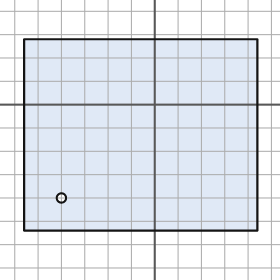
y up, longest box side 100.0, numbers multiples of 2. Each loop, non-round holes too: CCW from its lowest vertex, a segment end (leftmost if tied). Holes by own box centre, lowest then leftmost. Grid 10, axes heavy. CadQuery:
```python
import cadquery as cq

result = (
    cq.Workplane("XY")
    .moveTo(-56.0, -54.0)
    .lineTo(44.0, -54.0)
    .lineTo(44.0, 28.0)
    .lineTo(-56.0, 28.0)
    .close()
    .moveTo(-40.0, -40.0)
    .circle(2.0)
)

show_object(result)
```